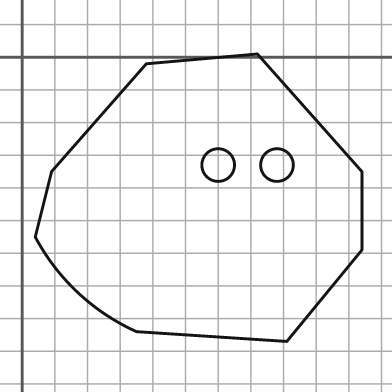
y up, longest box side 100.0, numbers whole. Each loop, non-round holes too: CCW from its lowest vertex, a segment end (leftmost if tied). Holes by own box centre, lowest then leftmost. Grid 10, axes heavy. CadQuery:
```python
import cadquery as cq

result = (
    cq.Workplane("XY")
    .moveTo(81.0, -87.0)
    .lineTo(104.0, -59.0)
    .lineTo(104.0, -35.0)
    .lineTo(72.0, 1.0)
    .lineTo(38.0, -2.0)
    .lineTo(9.0, -35.0)
    .lineTo(4.0, -55.0)
    .threePointArc((17.0, -72.0), (35.0, -84.0))
    .close()
    .moveTo(60.0, -33.0)
    .circle(5.0)
    .moveTo(78.0, -33.0)
    .circle(5.0)
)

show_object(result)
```